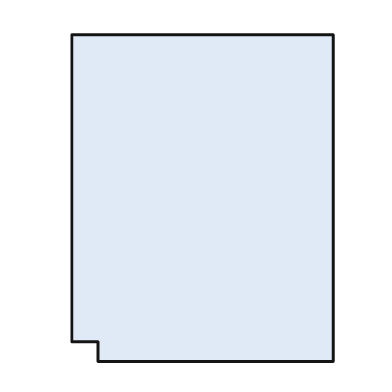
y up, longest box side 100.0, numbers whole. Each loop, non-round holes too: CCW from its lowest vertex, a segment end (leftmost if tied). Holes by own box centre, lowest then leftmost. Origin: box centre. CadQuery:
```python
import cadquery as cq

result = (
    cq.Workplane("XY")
    .moveTo(-32.0, -50.0)
    .lineTo(40.0, -50.0)
    .lineTo(40.0, 50.0)
    .lineTo(-40.0, 50.0)
    .lineTo(-40.0, -44.0)
    .lineTo(-32.0, -44.0)
    .close()
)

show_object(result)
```